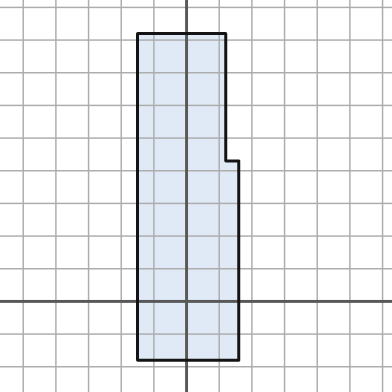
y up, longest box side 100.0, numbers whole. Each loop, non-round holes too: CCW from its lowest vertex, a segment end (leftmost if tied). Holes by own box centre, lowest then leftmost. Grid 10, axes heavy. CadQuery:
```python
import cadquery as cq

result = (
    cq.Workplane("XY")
    .moveTo(-15.0, -18.0)
    .lineTo(16.0, -18.0)
    .lineTo(16.0, 43.0)
    .lineTo(12.0, 43.0)
    .lineTo(12.0, 82.0)
    .lineTo(-15.0, 82.0)
    .close()
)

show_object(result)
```